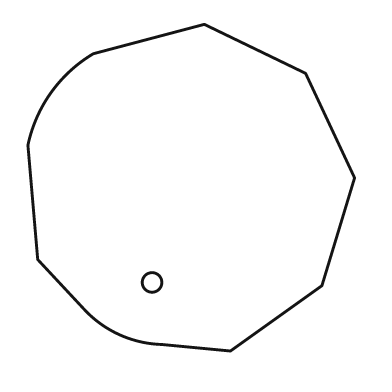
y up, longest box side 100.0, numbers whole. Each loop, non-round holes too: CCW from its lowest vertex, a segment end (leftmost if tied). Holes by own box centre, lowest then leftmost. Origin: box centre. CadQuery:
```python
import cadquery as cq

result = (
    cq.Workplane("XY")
    .moveTo(12.0, -50.0)
    .lineTo(40.0, -30.0)
    .lineTo(50.0, 3.0)
    .lineTo(35.0, 35.0)
    .lineTo(4.0, 50.0)
    .lineTo(-30.0, 41.0)
    .threePointArc((-43.0, 29.0), (-50.0, 13.0))
    .lineTo(-47.0, -22.0)
    .lineTo(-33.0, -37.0)
    .threePointArc((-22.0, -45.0), (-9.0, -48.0))
    .close()
    .moveTo(-12.0, -29.0)
    .circle(3.0)
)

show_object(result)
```